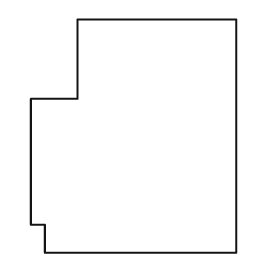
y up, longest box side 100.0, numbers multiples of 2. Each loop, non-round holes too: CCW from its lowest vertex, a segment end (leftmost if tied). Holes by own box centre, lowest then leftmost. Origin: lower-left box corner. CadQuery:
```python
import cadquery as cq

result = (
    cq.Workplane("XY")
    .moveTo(6.0, 0.0)
    .lineTo(88.0, 0.0)
    .lineTo(88.0, 100.0)
    .lineTo(20.0, 100.0)
    .lineTo(20.0, 66.0)
    .lineTo(0.0, 66.0)
    .lineTo(0.0, 12.0)
    .lineTo(6.0, 12.0)
    .close()
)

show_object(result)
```